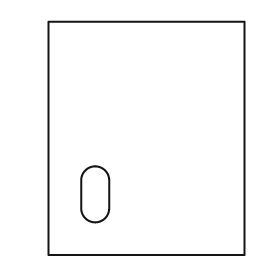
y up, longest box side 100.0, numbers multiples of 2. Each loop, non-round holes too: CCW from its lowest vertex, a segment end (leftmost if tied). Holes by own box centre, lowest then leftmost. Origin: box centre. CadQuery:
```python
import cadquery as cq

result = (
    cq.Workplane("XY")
    .moveTo(-42.0, -50.0)
    .lineTo(42.0, -50.0)
    .lineTo(42.0, 50.0)
    .lineTo(-42.0, 50.0)
    .close()
    .moveTo(-28.0, -30.0)
    .threePointArc((-22.0, -36.0), (-16.0, -30.0))
    .lineTo(-16.0, -18.0)
    .threePointArc((-22.0, -12.0), (-28.0, -18.0))
    .close()
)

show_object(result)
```